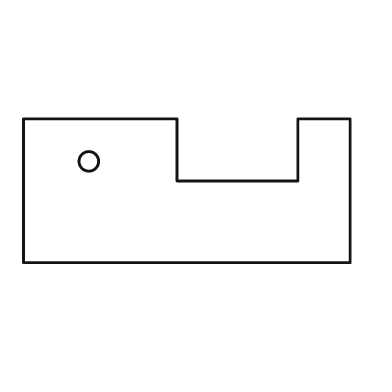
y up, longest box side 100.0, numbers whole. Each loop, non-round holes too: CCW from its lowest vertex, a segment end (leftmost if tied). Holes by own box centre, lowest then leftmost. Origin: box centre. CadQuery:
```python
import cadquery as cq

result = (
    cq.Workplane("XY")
    .moveTo(-50.0, -22.0)
    .lineTo(50.0, -22.0)
    .lineTo(50.0, 22.0)
    .lineTo(34.0, 22.0)
    .lineTo(34.0, 3.0)
    .lineTo(-3.0, 3.0)
    .lineTo(-3.0, 22.0)
    .lineTo(-50.0, 22.0)
    .close()
    .moveTo(-30.0, 9.0)
    .circle(3.0)
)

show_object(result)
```